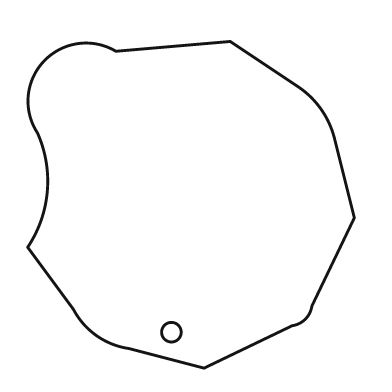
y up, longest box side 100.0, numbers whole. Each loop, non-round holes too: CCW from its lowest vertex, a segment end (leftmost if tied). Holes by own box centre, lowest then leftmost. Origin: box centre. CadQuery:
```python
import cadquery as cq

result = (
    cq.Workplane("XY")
    .moveTo(4.0, -50.0)
    .lineTo(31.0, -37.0)
    .threePointArc((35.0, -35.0), (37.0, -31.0))
    .lineTo(50.0, -4.0)
    .lineTo(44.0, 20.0)
    .threePointArc((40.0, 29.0), (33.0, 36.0))
    .lineTo(12.0, 50.0)
    .lineTo(-23.0, 47.0)
    .threePointArc((-45.0, 44.0), (-47.0, 22.0))
    .threePointArc((-44.0, 4.0), (-50.0, -13.0))
    .lineTo(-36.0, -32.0)
    .threePointArc((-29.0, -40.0), (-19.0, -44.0))
    .close()
    .moveTo(-6.0, -39.0)
    .circle(3.0)
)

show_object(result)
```